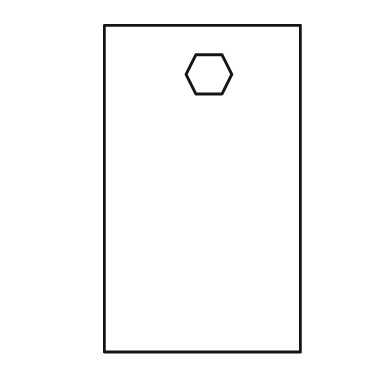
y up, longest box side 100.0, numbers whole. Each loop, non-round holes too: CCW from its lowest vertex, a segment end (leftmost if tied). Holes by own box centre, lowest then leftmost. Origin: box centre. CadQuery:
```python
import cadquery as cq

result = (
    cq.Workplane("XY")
    .moveTo(-30.0, -50.0)
    .lineTo(30.0, -50.0)
    .lineTo(30.0, 50.0)
    .lineTo(-30.0, 50.0)
    .close()
    .moveTo(-2.0, 29.0)
    .lineTo(6.0, 29.0)
    .lineTo(9.0, 35.0)
    .lineTo(6.0, 41.0)
    .lineTo(-2.0, 41.0)
    .lineTo(-5.0, 35.0)
    .close()
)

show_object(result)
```